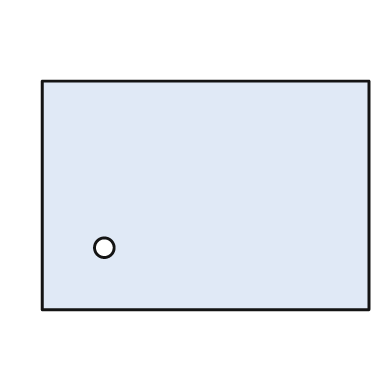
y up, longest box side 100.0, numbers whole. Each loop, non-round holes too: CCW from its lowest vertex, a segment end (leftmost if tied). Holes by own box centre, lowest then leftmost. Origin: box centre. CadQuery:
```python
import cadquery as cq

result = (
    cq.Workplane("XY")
    .moveTo(-50.0, -35.0)
    .lineTo(50.0, -35.0)
    .lineTo(50.0, 35.0)
    .lineTo(-50.0, 35.0)
    .close()
    .moveTo(-31.0, -16.0)
    .circle(3.0)
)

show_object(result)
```